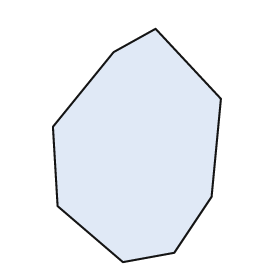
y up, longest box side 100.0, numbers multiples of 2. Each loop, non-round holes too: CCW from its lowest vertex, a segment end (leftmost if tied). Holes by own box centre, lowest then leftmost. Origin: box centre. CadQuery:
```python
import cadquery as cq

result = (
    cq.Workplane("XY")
    .moveTo(-6.0, -50.0)
    .lineTo(16.0, -46.0)
    .lineTo(32.0, -22.0)
    .lineTo(36.0, 20.0)
    .lineTo(8.0, 50.0)
    .lineTo(-10.0, 40.0)
    .lineTo(-36.0, 8.0)
    .lineTo(-34.0, -26.0)
    .close()
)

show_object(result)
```